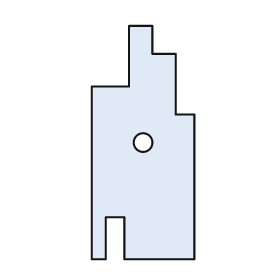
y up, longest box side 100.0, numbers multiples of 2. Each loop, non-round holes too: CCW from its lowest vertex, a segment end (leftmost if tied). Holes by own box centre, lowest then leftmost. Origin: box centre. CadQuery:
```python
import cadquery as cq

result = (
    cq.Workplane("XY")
    .moveTo(-22.0, -50.0)
    .lineTo(-16.0, -50.0)
    .lineTo(-16.0, -32.0)
    .lineTo(-8.0, -32.0)
    .lineTo(-8.0, -50.0)
    .lineTo(22.0, -50.0)
    .lineTo(22.0, 12.0)
    .lineTo(14.0, 12.0)
    .lineTo(14.0, 38.0)
    .lineTo(4.0, 38.0)
    .lineTo(4.0, 50.0)
    .lineTo(-6.0, 50.0)
    .lineTo(-6.0, 24.0)
    .lineTo(-22.0, 24.0)
    .close()
    .moveTo(0.0, 0.0)
    .circle(4.0)
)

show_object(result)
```